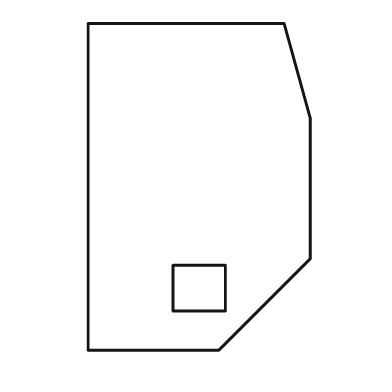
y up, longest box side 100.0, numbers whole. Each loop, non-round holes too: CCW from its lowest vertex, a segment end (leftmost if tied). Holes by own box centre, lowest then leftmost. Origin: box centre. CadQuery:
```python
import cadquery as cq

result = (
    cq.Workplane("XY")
    .moveTo(-34.0, -50.0)
    .lineTo(6.0, -50.0)
    .lineTo(34.0, -22.0)
    .lineTo(34.0, 21.0)
    .lineTo(26.0, 50.0)
    .lineTo(-34.0, 50.0)
    .close()
    .moveTo(-8.0, -38.0)
    .lineTo(8.0, -38.0)
    .lineTo(8.0, -24.0)
    .lineTo(-8.0, -24.0)
    .close()
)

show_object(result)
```